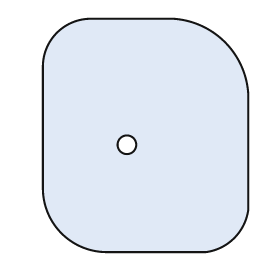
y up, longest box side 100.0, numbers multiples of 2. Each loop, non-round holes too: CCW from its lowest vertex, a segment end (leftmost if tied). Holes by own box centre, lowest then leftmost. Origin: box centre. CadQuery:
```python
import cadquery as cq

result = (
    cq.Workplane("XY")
    .moveTo(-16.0, -50.0)
    .lineTo(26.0, -50.0)
    .threePointArc((38.0, -44.0), (44.0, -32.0))
    .lineTo(44.0, 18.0)
    .threePointArc((34.0, 40.0), (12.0, 50.0))
    .lineTo(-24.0, 50.0)
    .threePointArc((-38.0, 44.0), (-44.0, 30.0))
    .lineTo(-44.0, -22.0)
    .threePointArc((-36.0, -42.0), (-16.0, -50.0))
    .close()
    .moveTo(-8.0, -4.0)
    .circle(4.0)
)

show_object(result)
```